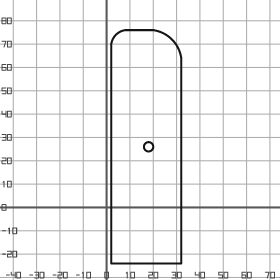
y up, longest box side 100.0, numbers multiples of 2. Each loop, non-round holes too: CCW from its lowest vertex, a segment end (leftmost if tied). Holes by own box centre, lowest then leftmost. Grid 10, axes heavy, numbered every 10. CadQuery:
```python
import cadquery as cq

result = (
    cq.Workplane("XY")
    .moveTo(2.0, -24.0)
    .lineTo(32.0, -24.0)
    .lineTo(32.0, 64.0)
    .threePointArc((28.0, 72.0), (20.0, 76.0))
    .lineTo(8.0, 76.0)
    .threePointArc((4.0, 74.0), (2.0, 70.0))
    .close()
    .moveTo(18.0, 26.0)
    .circle(2.0)
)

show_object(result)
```